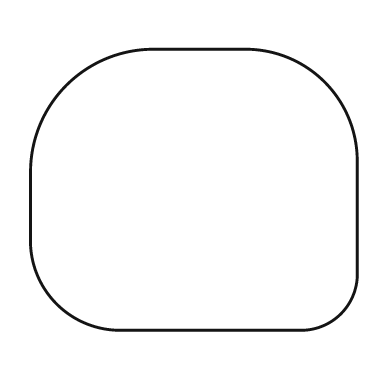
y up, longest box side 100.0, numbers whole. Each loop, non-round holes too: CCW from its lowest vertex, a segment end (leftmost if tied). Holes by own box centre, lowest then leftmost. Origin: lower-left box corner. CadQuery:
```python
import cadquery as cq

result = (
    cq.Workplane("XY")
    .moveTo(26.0, 0.0)
    .lineTo(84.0, 0.0)
    .threePointArc((95.0, 5.0), (100.0, 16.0))
    .lineTo(100.0, 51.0)
    .threePointArc((90.0, 76.0), (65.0, 86.0))
    .lineTo(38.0, 86.0)
    .threePointArc((11.0, 75.0), (0.0, 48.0))
    .lineTo(0.0, 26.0)
    .threePointArc((8.0, 8.0), (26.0, 0.0))
    .close()
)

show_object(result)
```